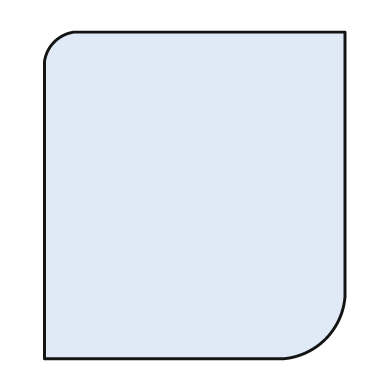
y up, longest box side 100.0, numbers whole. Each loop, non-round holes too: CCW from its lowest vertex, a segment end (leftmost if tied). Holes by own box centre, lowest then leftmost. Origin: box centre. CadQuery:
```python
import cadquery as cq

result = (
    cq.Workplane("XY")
    .moveTo(-46.0, -50.0)
    .lineTo(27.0, -50.0)
    .threePointArc((40.0, -44.0), (46.0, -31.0))
    .lineTo(46.0, 50.0)
    .lineTo(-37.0, 50.0)
    .threePointArc((-43.0, 47.0), (-46.0, 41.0))
    .close()
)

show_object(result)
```